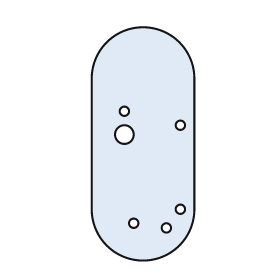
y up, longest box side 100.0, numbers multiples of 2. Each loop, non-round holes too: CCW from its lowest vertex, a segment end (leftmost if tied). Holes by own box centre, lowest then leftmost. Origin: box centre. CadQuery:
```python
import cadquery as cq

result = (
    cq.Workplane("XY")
    .moveTo(-22.0, -28.0)
    .threePointArc((0.0, -50.0), (22.0, -28.0))
    .lineTo(22.0, 28.0)
    .threePointArc((0.0, 50.0), (-22.0, 28.0))
    .close()
    .moveTo(10.0, -36.0)
    .circle(2.0)
    .moveTo(-4.0, -34.0)
    .circle(2.0)
    .moveTo(16.0, -28.0)
    .circle(2.0)
    .moveTo(-8.0, 4.0)
    .circle(4.0)
    .moveTo(16.0, 8.0)
    .circle(2.0)
    .moveTo(-8.0, 14.0)
    .circle(2.0)
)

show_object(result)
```